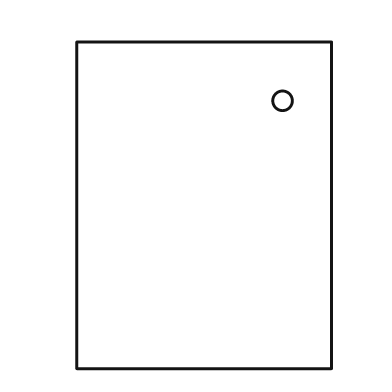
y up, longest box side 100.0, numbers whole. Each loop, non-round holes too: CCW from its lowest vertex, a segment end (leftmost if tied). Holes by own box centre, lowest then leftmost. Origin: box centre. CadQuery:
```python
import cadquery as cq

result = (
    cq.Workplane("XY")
    .moveTo(-39.0, -50.0)
    .lineTo(39.0, -50.0)
    .lineTo(39.0, 50.0)
    .lineTo(-39.0, 50.0)
    .close()
    .moveTo(24.0, 32.0)
    .circle(3.0)
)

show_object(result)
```